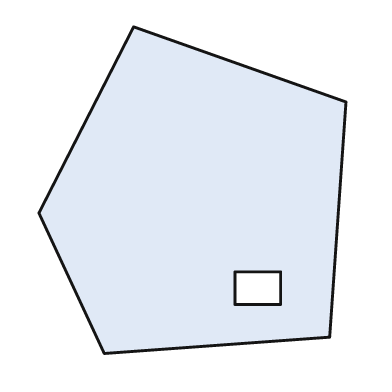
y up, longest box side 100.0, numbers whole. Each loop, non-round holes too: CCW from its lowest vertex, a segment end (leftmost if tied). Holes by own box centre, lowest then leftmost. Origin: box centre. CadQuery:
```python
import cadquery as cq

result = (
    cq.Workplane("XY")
    .moveTo(-27.0, -50.0)
    .lineTo(42.0, -45.0)
    .lineTo(47.0, 27.0)
    .lineTo(-18.0, 50.0)
    .lineTo(-47.0, -7.0)
    .close()
    .moveTo(13.0, -35.0)
    .lineTo(27.0, -35.0)
    .lineTo(27.0, -25.0)
    .lineTo(13.0, -25.0)
    .close()
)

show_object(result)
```